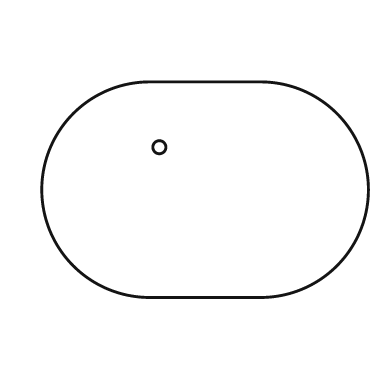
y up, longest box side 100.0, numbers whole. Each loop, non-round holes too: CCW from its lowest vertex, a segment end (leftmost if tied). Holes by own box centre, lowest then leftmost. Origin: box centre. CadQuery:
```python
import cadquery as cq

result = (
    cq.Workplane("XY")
    .moveTo(-17.0, -33.0)
    .lineTo(17.0, -33.0)
    .threePointArc((50.0, 0.0), (17.0, 33.0))
    .lineTo(-17.0, 33.0)
    .threePointArc((-50.0, 0.0), (-17.0, -33.0))
    .close()
    .moveTo(-14.0, 13.0)
    .circle(2.0)
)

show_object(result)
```